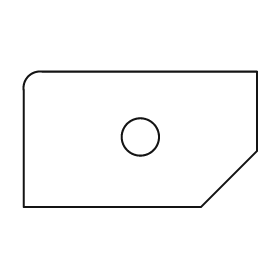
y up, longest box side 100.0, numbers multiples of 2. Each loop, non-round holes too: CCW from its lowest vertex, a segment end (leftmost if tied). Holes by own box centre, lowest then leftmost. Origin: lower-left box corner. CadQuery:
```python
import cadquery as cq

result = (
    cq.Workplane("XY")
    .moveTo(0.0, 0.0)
    .lineTo(76.0, 0.0)
    .lineTo(100.0, 24.0)
    .lineTo(100.0, 58.0)
    .lineTo(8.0, 58.0)
    .threePointArc((2.0, 56.0), (0.0, 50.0))
    .close()
    .moveTo(50.0, 30.0)
    .circle(8.0)
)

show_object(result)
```